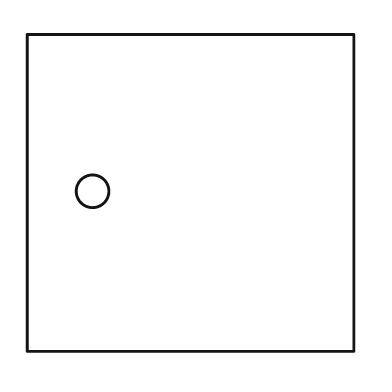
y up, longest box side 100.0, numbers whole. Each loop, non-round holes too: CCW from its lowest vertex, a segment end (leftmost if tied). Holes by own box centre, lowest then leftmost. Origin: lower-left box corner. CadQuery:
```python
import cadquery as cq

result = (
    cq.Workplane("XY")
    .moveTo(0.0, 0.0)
    .lineTo(100.0, 0.0)
    .lineTo(100.0, 97.0)
    .lineTo(0.0, 97.0)
    .close()
    .moveTo(20.0, 49.0)
    .circle(5.0)
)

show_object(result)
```